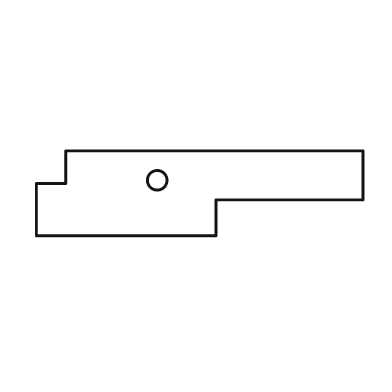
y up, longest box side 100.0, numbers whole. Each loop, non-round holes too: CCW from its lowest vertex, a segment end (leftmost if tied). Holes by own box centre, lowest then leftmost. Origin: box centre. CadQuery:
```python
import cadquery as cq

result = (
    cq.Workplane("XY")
    .moveTo(-50.0, -13.0)
    .lineTo(5.0, -13.0)
    .lineTo(5.0, -2.0)
    .lineTo(50.0, -2.0)
    .lineTo(50.0, 13.0)
    .lineTo(-41.0, 13.0)
    .lineTo(-41.0, 3.0)
    .lineTo(-50.0, 3.0)
    .close()
    .moveTo(-13.0, 4.0)
    .circle(3.0)
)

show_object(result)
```